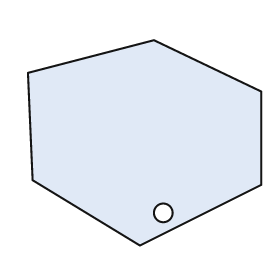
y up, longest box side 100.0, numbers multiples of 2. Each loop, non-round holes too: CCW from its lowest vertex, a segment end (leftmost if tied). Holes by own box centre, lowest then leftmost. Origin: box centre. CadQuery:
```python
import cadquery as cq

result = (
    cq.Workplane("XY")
    .moveTo(-2.0, -44.0)
    .lineTo(50.0, -18.0)
    .lineTo(50.0, 22.0)
    .lineTo(4.0, 44.0)
    .lineTo(-50.0, 30.0)
    .lineTo(-48.0, -16.0)
    .close()
    .moveTo(8.0, -30.0)
    .circle(4.0)
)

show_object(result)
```